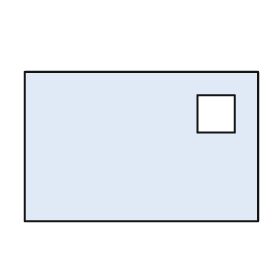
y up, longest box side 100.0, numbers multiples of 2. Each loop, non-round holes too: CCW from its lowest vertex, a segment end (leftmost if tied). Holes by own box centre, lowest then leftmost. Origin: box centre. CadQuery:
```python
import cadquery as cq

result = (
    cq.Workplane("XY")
    .moveTo(-50.0, -32.0)
    .lineTo(50.0, -32.0)
    .lineTo(50.0, 32.0)
    .lineTo(-50.0, 32.0)
    .close()
    .moveTo(24.0, 6.0)
    .lineTo(40.0, 6.0)
    .lineTo(40.0, 22.0)
    .lineTo(24.0, 22.0)
    .close()
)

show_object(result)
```